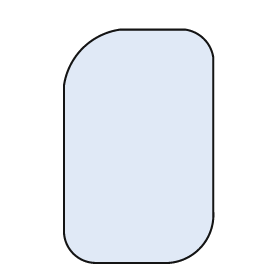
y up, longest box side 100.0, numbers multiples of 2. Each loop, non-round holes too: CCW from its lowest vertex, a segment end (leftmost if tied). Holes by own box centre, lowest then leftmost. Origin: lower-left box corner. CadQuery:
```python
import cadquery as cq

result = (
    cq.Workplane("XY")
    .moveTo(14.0, 0.0)
    .lineTo(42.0, 0.0)
    .threePointArc((58.0, 6.0), (64.0, 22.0))
    .lineTo(64.0, 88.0)
    .threePointArc((60.0, 96.0), (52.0, 100.0))
    .lineTo(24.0, 100.0)
    .threePointArc((8.0, 92.0), (0.0, 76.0))
    .lineTo(0.0, 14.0)
    .threePointArc((4.0, 4.0), (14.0, 0.0))
    .close()
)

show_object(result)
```